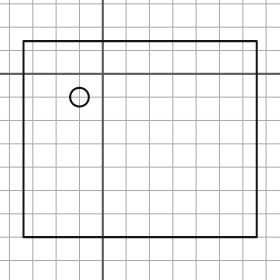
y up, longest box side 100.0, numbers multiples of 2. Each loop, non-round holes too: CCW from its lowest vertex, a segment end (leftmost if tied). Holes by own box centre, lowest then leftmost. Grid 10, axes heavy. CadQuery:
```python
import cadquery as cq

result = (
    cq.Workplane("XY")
    .moveTo(-34.0, -70.0)
    .lineTo(66.0, -70.0)
    .lineTo(66.0, 14.0)
    .lineTo(-34.0, 14.0)
    .close()
    .moveTo(-10.0, -10.0)
    .circle(4.0)
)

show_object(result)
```